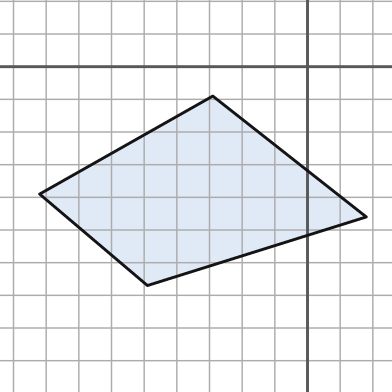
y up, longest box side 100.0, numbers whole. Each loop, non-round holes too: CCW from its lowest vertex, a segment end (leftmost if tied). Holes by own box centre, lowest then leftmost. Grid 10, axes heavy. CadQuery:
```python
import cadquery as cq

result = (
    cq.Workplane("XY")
    .moveTo(-49.0, -67.0)
    .lineTo(18.0, -46.0)
    .lineTo(-29.0, -9.0)
    .lineTo(-82.0, -39.0)
    .close()
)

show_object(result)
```